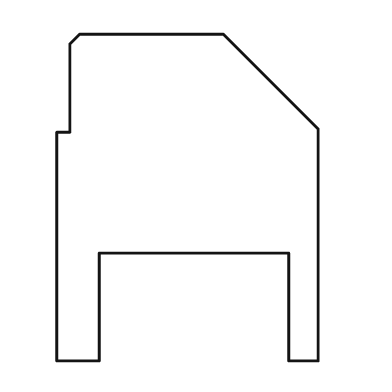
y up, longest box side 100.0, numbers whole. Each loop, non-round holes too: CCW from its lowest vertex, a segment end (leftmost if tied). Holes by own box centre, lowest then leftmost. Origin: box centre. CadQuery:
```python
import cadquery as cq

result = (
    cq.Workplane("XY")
    .moveTo(-40.0, -50.0)
    .lineTo(-27.0, -50.0)
    .lineTo(-27.0, -17.0)
    .lineTo(31.0, -17.0)
    .lineTo(31.0, -50.0)
    .lineTo(40.0, -50.0)
    .lineTo(40.0, 21.0)
    .lineTo(11.0, 50.0)
    .lineTo(-33.0, 50.0)
    .lineTo(-36.0, 47.0)
    .lineTo(-36.0, 20.0)
    .lineTo(-40.0, 20.0)
    .close()
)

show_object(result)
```